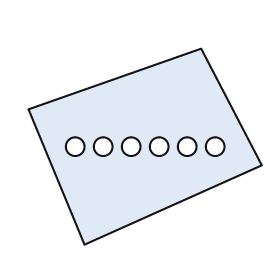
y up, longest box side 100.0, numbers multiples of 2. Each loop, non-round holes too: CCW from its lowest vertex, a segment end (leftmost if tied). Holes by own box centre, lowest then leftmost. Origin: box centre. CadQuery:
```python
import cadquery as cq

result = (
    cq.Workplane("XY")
    .moveTo(-26.0, -42.0)
    .lineTo(50.0, -8.0)
    .lineTo(24.0, 42.0)
    .lineTo(-50.0, 16.0)
    .close()
    .moveTo(-30.0, 0.0)
    .circle(4.0)
    .moveTo(-18.0, 0.0)
    .circle(4.0)
    .moveTo(-6.0, 0.0)
    .circle(4.0)
    .moveTo(6.0, 0.0)
    .circle(4.0)
    .moveTo(18.0, 0.0)
    .circle(4.0)
    .moveTo(30.0, 0.0)
    .circle(4.0)
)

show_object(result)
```